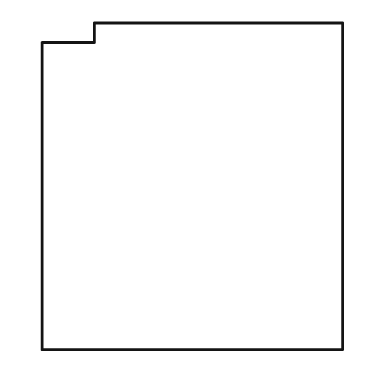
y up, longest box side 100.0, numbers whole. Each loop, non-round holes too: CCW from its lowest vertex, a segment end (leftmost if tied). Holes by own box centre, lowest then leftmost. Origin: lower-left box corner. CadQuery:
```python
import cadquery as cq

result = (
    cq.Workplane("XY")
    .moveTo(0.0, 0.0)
    .lineTo(92.0, 0.0)
    .lineTo(92.0, 100.0)
    .lineTo(16.0, 100.0)
    .lineTo(16.0, 94.0)
    .lineTo(0.0, 94.0)
    .close()
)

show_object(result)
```